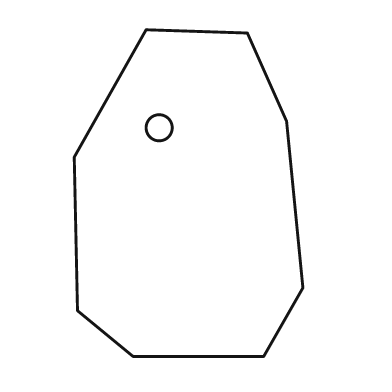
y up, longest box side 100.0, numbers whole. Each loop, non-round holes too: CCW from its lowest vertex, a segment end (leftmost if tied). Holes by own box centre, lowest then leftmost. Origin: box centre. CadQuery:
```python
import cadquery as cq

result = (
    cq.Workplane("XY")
    .moveTo(-17.0, -50.0)
    .lineTo(23.0, -50.0)
    .lineTo(35.0, -29.0)
    .lineTo(30.0, 22.0)
    .lineTo(18.0, 49.0)
    .lineTo(-13.0, 50.0)
    .lineTo(-35.0, 11.0)
    .lineTo(-34.0, -36.0)
    .close()
    .moveTo(-9.0, 20.0)
    .circle(4.0)
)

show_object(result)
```